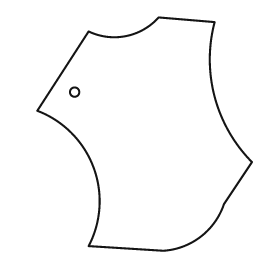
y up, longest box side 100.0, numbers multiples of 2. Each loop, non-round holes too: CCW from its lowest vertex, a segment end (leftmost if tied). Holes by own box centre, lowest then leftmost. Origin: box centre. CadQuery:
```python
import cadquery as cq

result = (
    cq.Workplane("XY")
    .moveTo(8.0, -50.0)
    .threePointArc((24.0, -44.0), (34.0, -30.0))
    .lineTo(46.0, -12.0)
    .threePointArc((30.0, 16.0), (30.0, 48.0))
    .lineTo(6.0, 50.0)
    .threePointArc((-8.0, 42.0), (-24.0, 44.0))
    .lineTo(-46.0, 10.0)
    .threePointArc((-22.0, -14.0), (-24.0, -48.0))
    .close()
    .moveTo(-30.0, 18.0)
    .circle(2.0)
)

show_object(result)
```